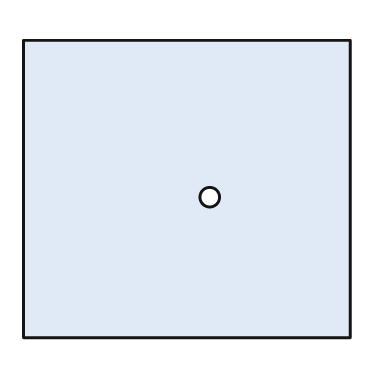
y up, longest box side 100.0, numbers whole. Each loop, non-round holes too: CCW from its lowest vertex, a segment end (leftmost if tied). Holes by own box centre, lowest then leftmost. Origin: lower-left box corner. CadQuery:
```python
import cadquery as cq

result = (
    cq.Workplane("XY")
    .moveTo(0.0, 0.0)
    .lineTo(100.0, 0.0)
    .lineTo(100.0, 91.0)
    .lineTo(0.0, 91.0)
    .close()
    .moveTo(57.0, 43.0)
    .circle(3.0)
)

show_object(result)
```